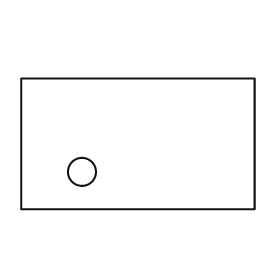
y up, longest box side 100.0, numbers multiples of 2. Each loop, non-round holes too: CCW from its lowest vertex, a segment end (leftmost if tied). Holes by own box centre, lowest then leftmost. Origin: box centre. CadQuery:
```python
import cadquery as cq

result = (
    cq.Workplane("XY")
    .moveTo(-50.0, -28.0)
    .lineTo(50.0, -28.0)
    .lineTo(50.0, 28.0)
    .lineTo(-50.0, 28.0)
    .close()
    .moveTo(-24.0, -12.0)
    .circle(6.0)
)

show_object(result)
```